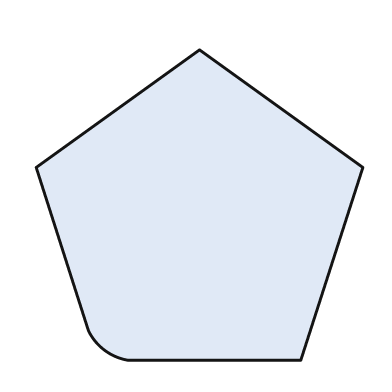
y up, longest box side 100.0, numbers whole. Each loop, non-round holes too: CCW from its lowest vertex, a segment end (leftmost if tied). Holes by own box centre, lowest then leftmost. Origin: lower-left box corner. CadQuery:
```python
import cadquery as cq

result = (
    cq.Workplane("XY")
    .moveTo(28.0, 0.0)
    .lineTo(81.0, 0.0)
    .lineTo(100.0, 59.0)
    .lineTo(50.0, 95.0)
    .lineTo(0.0, 59.0)
    .lineTo(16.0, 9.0)
    .threePointArc((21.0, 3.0), (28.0, 0.0))
    .close()
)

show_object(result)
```